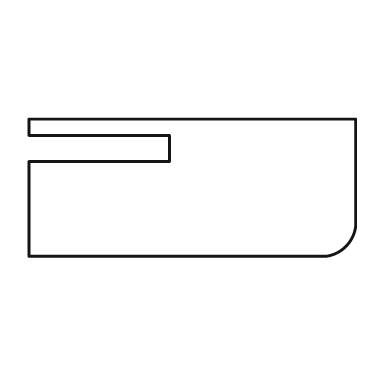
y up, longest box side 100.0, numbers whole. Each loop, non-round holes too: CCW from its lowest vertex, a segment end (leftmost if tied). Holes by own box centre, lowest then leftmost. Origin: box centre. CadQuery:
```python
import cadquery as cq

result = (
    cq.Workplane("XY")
    .moveTo(-50.0, -21.0)
    .lineTo(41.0, -21.0)
    .threePointArc((47.0, -18.0), (50.0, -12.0))
    .lineTo(50.0, 21.0)
    .lineTo(-50.0, 21.0)
    .lineTo(-50.0, 16.0)
    .lineTo(-7.0, 16.0)
    .lineTo(-7.0, 8.0)
    .lineTo(-50.0, 8.0)
    .close()
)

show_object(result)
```